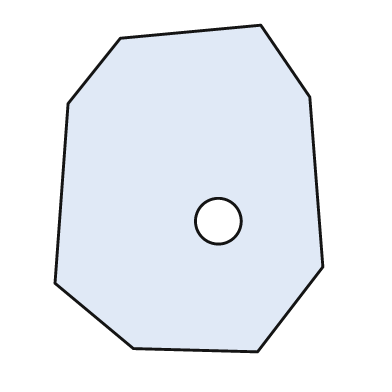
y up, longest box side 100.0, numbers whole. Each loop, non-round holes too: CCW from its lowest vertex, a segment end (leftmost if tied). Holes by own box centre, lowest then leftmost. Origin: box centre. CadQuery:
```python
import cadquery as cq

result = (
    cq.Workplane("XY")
    .moveTo(21.0, -50.0)
    .lineTo(41.0, -24.0)
    .lineTo(37.0, 28.0)
    .lineTo(22.0, 50.0)
    .lineTo(-21.0, 46.0)
    .lineTo(-37.0, 26.0)
    .lineTo(-41.0, -29.0)
    .lineTo(-17.0, -49.0)
    .close()
    .moveTo(9.0, -10.0)
    .circle(7.0)
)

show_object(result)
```